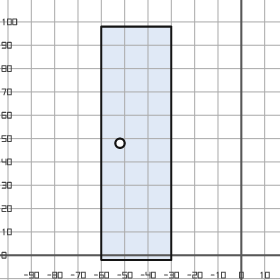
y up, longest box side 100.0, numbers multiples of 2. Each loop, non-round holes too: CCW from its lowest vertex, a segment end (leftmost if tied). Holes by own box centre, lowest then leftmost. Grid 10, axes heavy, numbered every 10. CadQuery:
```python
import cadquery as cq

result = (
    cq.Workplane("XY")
    .moveTo(-60.0, -2.0)
    .lineTo(-30.0, -2.0)
    .lineTo(-30.0, 98.0)
    .lineTo(-60.0, 98.0)
    .close()
    .moveTo(-52.0, 48.0)
    .circle(2.0)
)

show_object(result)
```